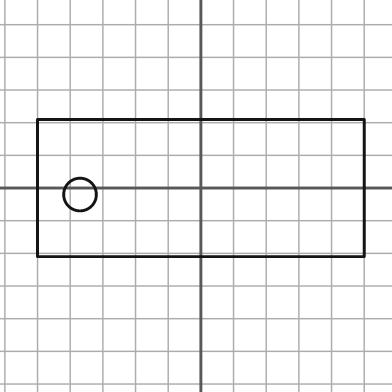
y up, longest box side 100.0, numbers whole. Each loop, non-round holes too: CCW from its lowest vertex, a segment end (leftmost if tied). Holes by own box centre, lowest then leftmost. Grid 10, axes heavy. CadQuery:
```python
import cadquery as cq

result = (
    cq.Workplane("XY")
    .moveTo(-50.0, -21.0)
    .lineTo(50.0, -21.0)
    .lineTo(50.0, 21.0)
    .lineTo(-50.0, 21.0)
    .close()
    .moveTo(-37.0, -2.0)
    .circle(5.0)
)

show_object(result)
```